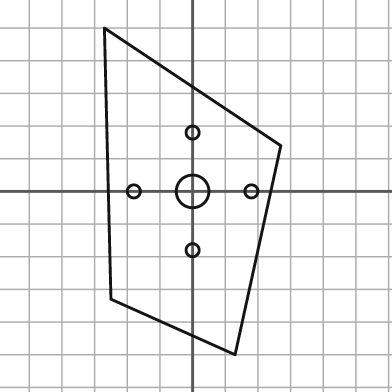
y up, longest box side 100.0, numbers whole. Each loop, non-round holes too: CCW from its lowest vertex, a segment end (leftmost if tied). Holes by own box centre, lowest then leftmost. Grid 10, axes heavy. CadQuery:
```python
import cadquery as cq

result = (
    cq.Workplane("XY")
    .moveTo(13.0, -50.0)
    .lineTo(27.0, 14.0)
    .lineTo(-27.0, 50.0)
    .lineTo(-25.0, -33.0)
    .close()
    .moveTo(0.0, -18.0)
    .circle(2.0)
    .moveTo(-18.0, 0.0)
    .circle(2.0)
    .moveTo(0.0, 0.0)
    .circle(5.0)
    .moveTo(18.0, 0.0)
    .circle(2.0)
    .moveTo(0.0, 18.0)
    .circle(2.0)
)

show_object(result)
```